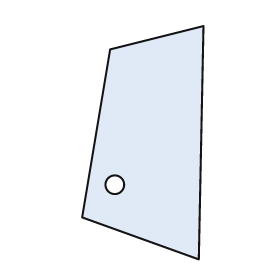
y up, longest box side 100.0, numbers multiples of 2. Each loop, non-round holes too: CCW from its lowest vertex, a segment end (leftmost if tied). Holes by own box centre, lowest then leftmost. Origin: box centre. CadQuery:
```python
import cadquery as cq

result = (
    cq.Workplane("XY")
    .moveTo(24.0, -50.0)
    .lineTo(26.0, 50.0)
    .lineTo(-14.0, 40.0)
    .lineTo(-26.0, -32.0)
    .close()
    .moveTo(-12.0, -18.0)
    .circle(4.0)
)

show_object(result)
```